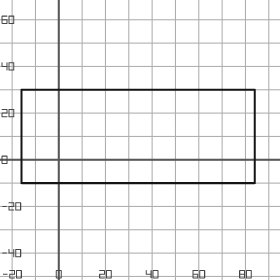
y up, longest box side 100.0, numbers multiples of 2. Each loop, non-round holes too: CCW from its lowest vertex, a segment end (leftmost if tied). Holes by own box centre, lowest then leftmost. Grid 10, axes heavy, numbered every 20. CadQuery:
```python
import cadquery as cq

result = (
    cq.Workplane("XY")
    .moveTo(-16.0, -10.0)
    .lineTo(84.0, -10.0)
    .lineTo(84.0, 30.0)
    .lineTo(-16.0, 30.0)
    .close()
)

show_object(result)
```